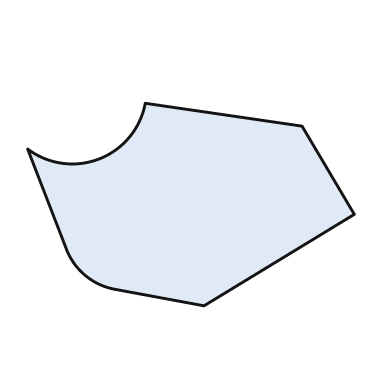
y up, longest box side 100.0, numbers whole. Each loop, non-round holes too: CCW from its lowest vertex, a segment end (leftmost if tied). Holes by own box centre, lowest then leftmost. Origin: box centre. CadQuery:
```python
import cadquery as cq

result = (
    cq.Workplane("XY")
    .moveTo(4.0, -31.0)
    .lineTo(50.0, -3.0)
    .lineTo(34.0, 24.0)
    .lineTo(-14.0, 31.0)
    .threePointArc((-28.0, 14.0), (-50.0, 17.0))
    .lineTo(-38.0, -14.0)
    .threePointArc((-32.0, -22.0), (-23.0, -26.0))
    .close()
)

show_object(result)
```